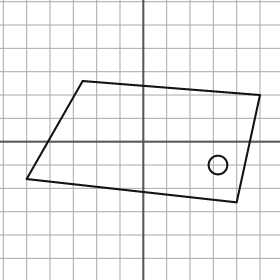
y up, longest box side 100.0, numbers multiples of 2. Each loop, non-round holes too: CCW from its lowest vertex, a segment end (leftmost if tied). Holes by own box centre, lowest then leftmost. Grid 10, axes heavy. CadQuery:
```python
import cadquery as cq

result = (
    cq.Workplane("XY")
    .moveTo(40.0, -26.0)
    .lineTo(50.0, 20.0)
    .lineTo(-26.0, 26.0)
    .lineTo(-50.0, -16.0)
    .close()
    .moveTo(32.0, -10.0)
    .circle(4.0)
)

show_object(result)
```